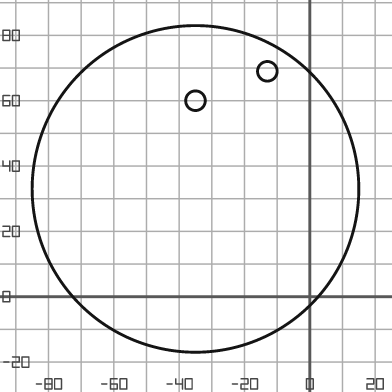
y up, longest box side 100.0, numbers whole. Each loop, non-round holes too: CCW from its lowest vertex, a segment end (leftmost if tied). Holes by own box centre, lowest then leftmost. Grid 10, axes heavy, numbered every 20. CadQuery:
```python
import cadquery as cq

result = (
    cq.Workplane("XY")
    .moveTo(-35.0, 33.0)
    .circle(50.0)
    .moveTo(-35.0, 60.0)
    .circle(3.0)
    .moveTo(-13.0, 69.0)
    .circle(3.0)
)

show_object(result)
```